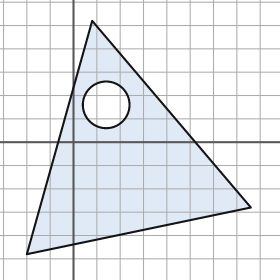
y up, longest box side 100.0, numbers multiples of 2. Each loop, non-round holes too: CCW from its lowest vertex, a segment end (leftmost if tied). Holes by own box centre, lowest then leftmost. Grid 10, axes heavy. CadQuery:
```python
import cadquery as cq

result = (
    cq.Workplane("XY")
    .moveTo(-20.0, -48.0)
    .lineTo(76.0, -28.0)
    .lineTo(8.0, 52.0)
    .close()
    .moveTo(14.0, 16.0)
    .circle(10.0)
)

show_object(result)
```